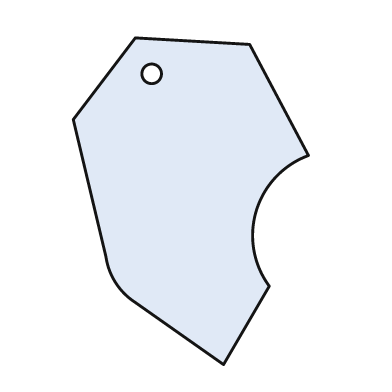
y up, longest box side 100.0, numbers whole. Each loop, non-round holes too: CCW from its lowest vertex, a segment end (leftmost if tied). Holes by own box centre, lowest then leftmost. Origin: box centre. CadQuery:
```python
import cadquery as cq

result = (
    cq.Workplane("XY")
    .moveTo(10.0, -50.0)
    .lineTo(24.0, -26.0)
    .threePointArc((20.0, -3.0), (36.0, 14.0))
    .lineTo(18.0, 48.0)
    .lineTo(-17.0, 50.0)
    .lineTo(-36.0, 25.0)
    .lineTo(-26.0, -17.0)
    .threePointArc((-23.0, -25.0), (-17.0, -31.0))
    .close()
    .moveTo(-12.0, 39.0)
    .circle(3.0)
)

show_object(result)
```